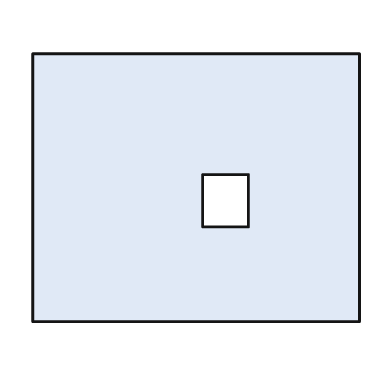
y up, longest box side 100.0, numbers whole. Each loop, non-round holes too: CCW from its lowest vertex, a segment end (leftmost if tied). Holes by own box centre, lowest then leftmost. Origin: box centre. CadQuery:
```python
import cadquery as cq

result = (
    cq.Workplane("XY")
    .moveTo(-50.0, -41.0)
    .lineTo(50.0, -41.0)
    .lineTo(50.0, 41.0)
    .lineTo(-50.0, 41.0)
    .close()
    .moveTo(2.0, -12.0)
    .lineTo(16.0, -12.0)
    .lineTo(16.0, 4.0)
    .lineTo(2.0, 4.0)
    .close()
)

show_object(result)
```